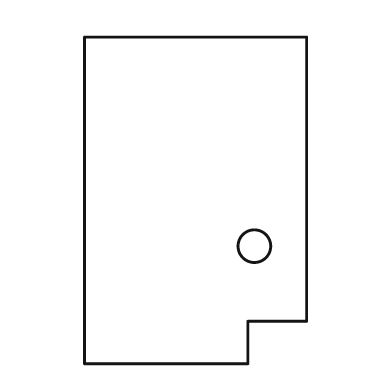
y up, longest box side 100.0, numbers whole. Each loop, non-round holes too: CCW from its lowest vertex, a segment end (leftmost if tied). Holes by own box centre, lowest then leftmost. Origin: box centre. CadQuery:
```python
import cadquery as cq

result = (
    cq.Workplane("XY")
    .moveTo(-34.0, -50.0)
    .lineTo(16.0, -50.0)
    .lineTo(16.0, -37.0)
    .lineTo(34.0, -37.0)
    .lineTo(34.0, 50.0)
    .lineTo(-34.0, 50.0)
    .close()
    .moveTo(18.0, -14.0)
    .circle(5.0)
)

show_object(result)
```